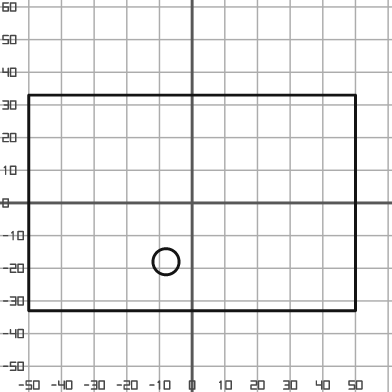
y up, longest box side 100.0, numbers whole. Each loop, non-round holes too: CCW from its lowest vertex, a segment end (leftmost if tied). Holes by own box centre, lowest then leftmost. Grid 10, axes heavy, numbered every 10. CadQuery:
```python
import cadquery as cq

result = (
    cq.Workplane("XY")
    .moveTo(-50.0, -33.0)
    .lineTo(50.0, -33.0)
    .lineTo(50.0, 33.0)
    .lineTo(-50.0, 33.0)
    .close()
    .moveTo(-8.0, -18.0)
    .circle(4.0)
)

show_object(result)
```